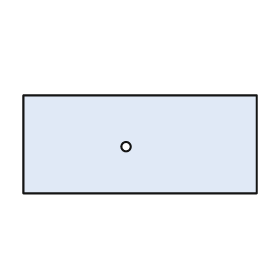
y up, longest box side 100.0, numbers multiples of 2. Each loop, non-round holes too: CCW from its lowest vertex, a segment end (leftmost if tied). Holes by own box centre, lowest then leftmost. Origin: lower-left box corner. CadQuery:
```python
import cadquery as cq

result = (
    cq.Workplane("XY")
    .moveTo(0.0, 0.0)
    .lineTo(100.0, 0.0)
    .lineTo(100.0, 42.0)
    .lineTo(0.0, 42.0)
    .close()
    .moveTo(44.0, 20.0)
    .circle(2.0)
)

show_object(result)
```